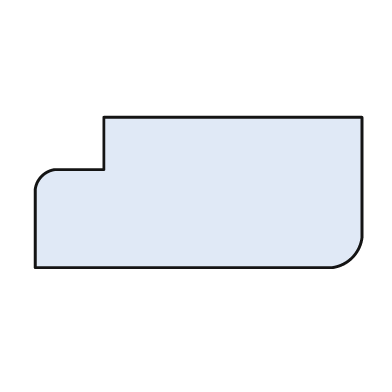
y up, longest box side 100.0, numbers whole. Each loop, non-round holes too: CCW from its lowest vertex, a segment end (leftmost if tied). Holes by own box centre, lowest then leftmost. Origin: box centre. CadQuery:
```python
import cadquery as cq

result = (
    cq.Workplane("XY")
    .moveTo(-50.0, -23.0)
    .lineTo(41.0, -23.0)
    .threePointArc((47.0, -20.0), (50.0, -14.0))
    .lineTo(50.0, 23.0)
    .lineTo(-29.0, 23.0)
    .lineTo(-29.0, 7.0)
    .lineTo(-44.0, 7.0)
    .threePointArc((-48.0, 5.0), (-50.0, 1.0))
    .close()
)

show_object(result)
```